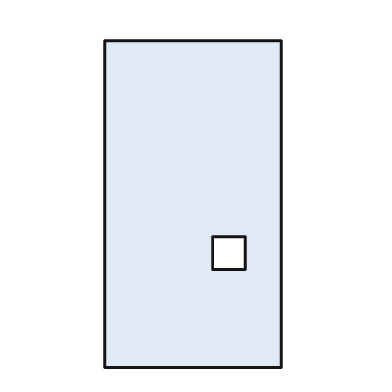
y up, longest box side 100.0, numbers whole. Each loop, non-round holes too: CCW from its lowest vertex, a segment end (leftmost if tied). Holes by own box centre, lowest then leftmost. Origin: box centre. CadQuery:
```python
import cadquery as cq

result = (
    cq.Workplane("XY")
    .moveTo(-27.0, -50.0)
    .lineTo(27.0, -50.0)
    .lineTo(27.0, 50.0)
    .lineTo(-27.0, 50.0)
    .close()
    .moveTo(6.0, -20.0)
    .lineTo(16.0, -20.0)
    .lineTo(16.0, -10.0)
    .lineTo(6.0, -10.0)
    .close()
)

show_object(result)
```